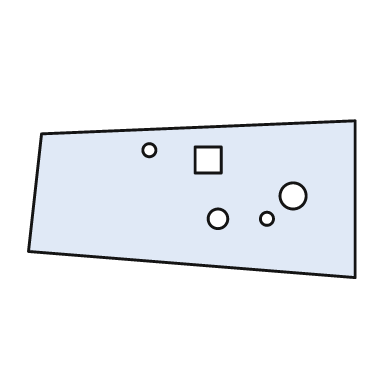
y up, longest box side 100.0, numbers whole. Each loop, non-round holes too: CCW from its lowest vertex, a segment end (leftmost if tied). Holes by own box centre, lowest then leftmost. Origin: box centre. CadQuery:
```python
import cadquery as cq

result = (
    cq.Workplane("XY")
    .moveTo(50.0, -24.0)
    .lineTo(50.0, 24.0)
    .lineTo(-46.0, 20.0)
    .lineTo(-50.0, -16.0)
    .close()
    .moveTo(8.0, -6.0)
    .circle(3.0)
    .moveTo(23.0, -6.0)
    .circle(2.0)
    .moveTo(31.0, 1.0)
    .circle(4.0)
    .moveTo(1.0, 8.0)
    .lineTo(9.0, 8.0)
    .lineTo(9.0, 16.0)
    .lineTo(1.0, 16.0)
    .close()
    .moveTo(-13.0, 15.0)
    .circle(2.0)
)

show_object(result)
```